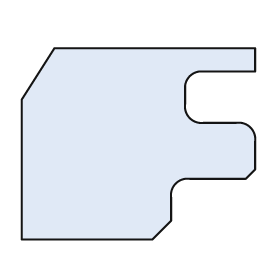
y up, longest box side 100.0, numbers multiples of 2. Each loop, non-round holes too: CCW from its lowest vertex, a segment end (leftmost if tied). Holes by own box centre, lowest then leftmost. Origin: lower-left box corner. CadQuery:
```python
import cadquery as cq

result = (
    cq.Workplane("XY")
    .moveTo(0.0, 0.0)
    .lineTo(56.0, 0.0)
    .lineTo(64.0, 8.0)
    .lineTo(64.0, 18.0)
    .threePointArc((66.0, 24.0), (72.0, 26.0))
    .lineTo(96.0, 26.0)
    .lineTo(100.0, 30.0)
    .lineTo(100.0, 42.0)
    .threePointArc((98.0, 48.0), (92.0, 50.0))
    .lineTo(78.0, 50.0)
    .threePointArc((72.0, 52.0), (70.0, 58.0))
    .lineTo(70.0, 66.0)
    .threePointArc((72.0, 70.0), (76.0, 72.0))
    .lineTo(100.0, 72.0)
    .lineTo(100.0, 82.0)
    .lineTo(14.0, 82.0)
    .lineTo(0.0, 60.0)
    .close()
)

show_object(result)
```